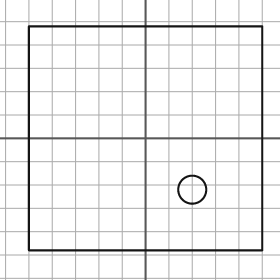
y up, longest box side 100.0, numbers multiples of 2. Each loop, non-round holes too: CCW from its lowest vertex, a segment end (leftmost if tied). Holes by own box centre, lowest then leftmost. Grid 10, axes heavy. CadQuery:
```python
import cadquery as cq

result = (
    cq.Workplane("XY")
    .moveTo(-50.0, -48.0)
    .lineTo(50.0, -48.0)
    .lineTo(50.0, 48.0)
    .lineTo(-50.0, 48.0)
    .close()
    .moveTo(20.0, -22.0)
    .circle(6.0)
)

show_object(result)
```